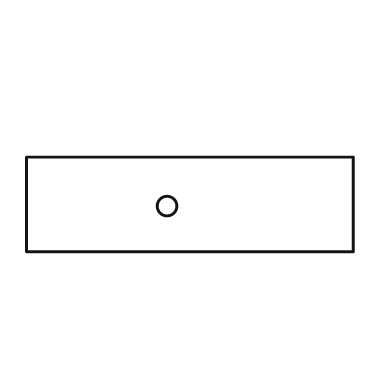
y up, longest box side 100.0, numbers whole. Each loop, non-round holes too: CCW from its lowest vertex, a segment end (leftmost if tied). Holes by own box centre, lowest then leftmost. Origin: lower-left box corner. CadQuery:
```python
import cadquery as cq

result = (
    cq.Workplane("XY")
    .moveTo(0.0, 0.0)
    .lineTo(100.0, 0.0)
    .lineTo(100.0, 29.0)
    .lineTo(0.0, 29.0)
    .close()
    .moveTo(43.0, 14.0)
    .circle(3.0)
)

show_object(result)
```